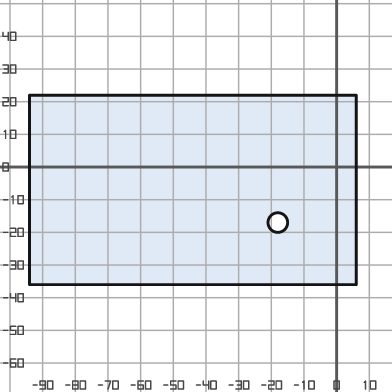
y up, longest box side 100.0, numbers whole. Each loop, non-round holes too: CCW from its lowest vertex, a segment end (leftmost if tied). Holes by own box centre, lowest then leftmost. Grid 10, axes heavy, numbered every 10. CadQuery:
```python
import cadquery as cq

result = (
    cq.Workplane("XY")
    .moveTo(-94.0, -36.0)
    .lineTo(6.0, -36.0)
    .lineTo(6.0, 22.0)
    .lineTo(-94.0, 22.0)
    .close()
    .moveTo(-18.0, -17.0)
    .circle(3.0)
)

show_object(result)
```